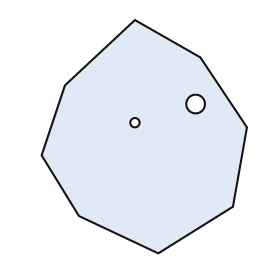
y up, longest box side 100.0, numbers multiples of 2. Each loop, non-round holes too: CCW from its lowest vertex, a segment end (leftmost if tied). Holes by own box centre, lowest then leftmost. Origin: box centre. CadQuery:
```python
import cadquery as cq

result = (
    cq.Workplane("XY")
    .moveTo(6.0, -50.0)
    .lineTo(38.0, -30.0)
    .lineTo(44.0, 4.0)
    .lineTo(24.0, 34.0)
    .lineTo(-4.0, 50.0)
    .lineTo(-34.0, 22.0)
    .lineTo(-44.0, -8.0)
    .lineTo(-28.0, -34.0)
    .close()
    .moveTo(-4.0, 6.0)
    .circle(2.0)
    .moveTo(22.0, 14.0)
    .circle(4.0)
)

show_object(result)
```